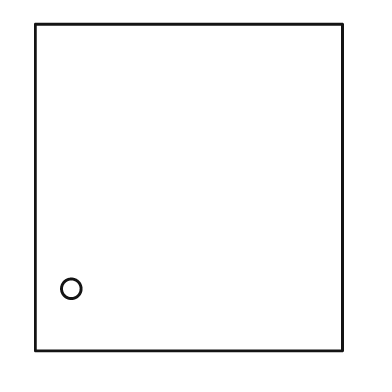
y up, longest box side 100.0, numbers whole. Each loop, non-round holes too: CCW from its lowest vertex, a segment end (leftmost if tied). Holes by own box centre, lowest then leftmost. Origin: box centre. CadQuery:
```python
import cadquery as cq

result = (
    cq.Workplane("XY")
    .moveTo(-47.0, -50.0)
    .lineTo(47.0, -50.0)
    .lineTo(47.0, 50.0)
    .lineTo(-47.0, 50.0)
    .close()
    .moveTo(-36.0, -31.0)
    .circle(3.0)
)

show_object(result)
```